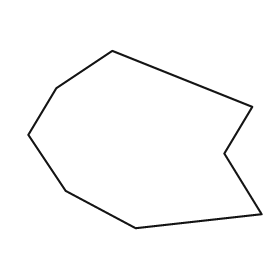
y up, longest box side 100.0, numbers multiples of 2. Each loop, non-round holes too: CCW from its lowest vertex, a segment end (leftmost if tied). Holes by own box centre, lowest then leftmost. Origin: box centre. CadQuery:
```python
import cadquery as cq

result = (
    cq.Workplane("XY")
    .moveTo(-4.0, -38.0)
    .lineTo(50.0, -32.0)
    .lineTo(34.0, -6.0)
    .lineTo(46.0, 14.0)
    .lineTo(-14.0, 38.0)
    .lineTo(-38.0, 22.0)
    .lineTo(-50.0, 2.0)
    .lineTo(-34.0, -22.0)
    .close()
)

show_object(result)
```